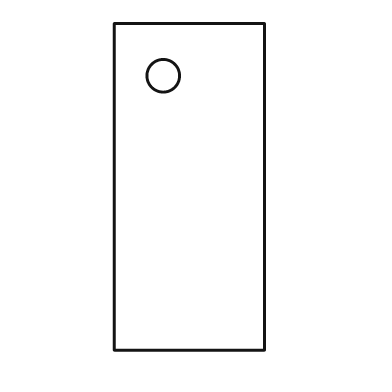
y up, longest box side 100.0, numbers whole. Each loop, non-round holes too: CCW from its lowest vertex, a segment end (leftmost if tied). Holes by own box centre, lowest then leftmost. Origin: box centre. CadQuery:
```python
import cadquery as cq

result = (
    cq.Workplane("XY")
    .moveTo(-23.0, -50.0)
    .lineTo(23.0, -50.0)
    .lineTo(23.0, 50.0)
    .lineTo(-23.0, 50.0)
    .close()
    .moveTo(-8.0, 34.0)
    .circle(5.0)
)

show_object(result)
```